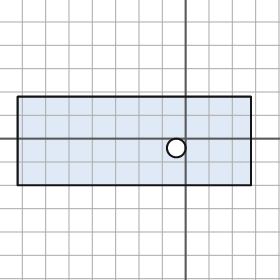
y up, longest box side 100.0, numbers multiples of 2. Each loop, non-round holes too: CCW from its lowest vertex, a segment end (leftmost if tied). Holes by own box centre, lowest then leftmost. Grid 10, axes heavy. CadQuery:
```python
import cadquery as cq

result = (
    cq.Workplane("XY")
    .moveTo(-72.0, -20.0)
    .lineTo(28.0, -20.0)
    .lineTo(28.0, 18.0)
    .lineTo(-72.0, 18.0)
    .close()
    .moveTo(-4.0, -4.0)
    .circle(4.0)
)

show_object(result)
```